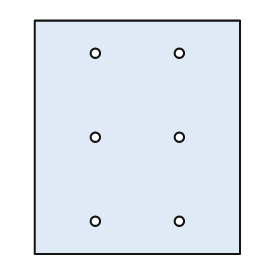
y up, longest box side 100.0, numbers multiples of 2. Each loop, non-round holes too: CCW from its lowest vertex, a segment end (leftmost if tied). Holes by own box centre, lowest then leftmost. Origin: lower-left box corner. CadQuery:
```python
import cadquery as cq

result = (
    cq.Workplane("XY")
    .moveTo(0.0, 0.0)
    .lineTo(88.0, 0.0)
    .lineTo(88.0, 100.0)
    .lineTo(0.0, 100.0)
    .close()
    .moveTo(26.0, 14.0)
    .circle(2.0)
    .moveTo(62.0, 14.0)
    .circle(2.0)
    .moveTo(26.0, 50.0)
    .circle(2.0)
    .moveTo(62.0, 50.0)
    .circle(2.0)
    .moveTo(26.0, 86.0)
    .circle(2.0)
    .moveTo(62.0, 86.0)
    .circle(2.0)
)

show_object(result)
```